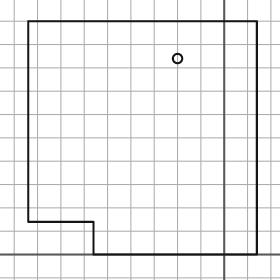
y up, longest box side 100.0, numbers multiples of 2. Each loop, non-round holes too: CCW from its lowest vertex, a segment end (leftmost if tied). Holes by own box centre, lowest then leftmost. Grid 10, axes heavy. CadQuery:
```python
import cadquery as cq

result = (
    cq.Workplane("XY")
    .moveTo(-56.0, 0.0)
    .lineTo(14.0, 0.0)
    .lineTo(14.0, 100.0)
    .lineTo(-84.0, 100.0)
    .lineTo(-84.0, 14.0)
    .lineTo(-56.0, 14.0)
    .close()
    .moveTo(-20.0, 84.0)
    .circle(2.0)
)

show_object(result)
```